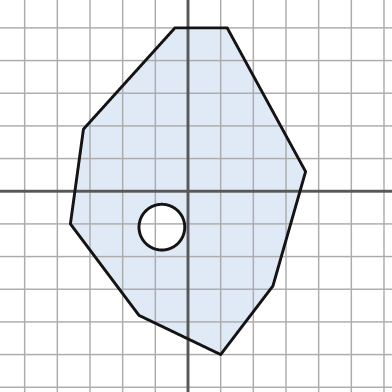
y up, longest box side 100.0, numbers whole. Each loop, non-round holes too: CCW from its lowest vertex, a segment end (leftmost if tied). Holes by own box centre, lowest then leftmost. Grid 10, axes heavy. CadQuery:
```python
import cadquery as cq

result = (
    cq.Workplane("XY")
    .moveTo(10.0, -50.0)
    .lineTo(26.0, -29.0)
    .lineTo(36.0, 6.0)
    .lineTo(12.0, 50.0)
    .lineTo(-4.0, 50.0)
    .lineTo(-32.0, 19.0)
    .lineTo(-36.0, -10.0)
    .lineTo(-15.0, -38.0)
    .close()
    .moveTo(-8.0, -11.0)
    .circle(7.0)
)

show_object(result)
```